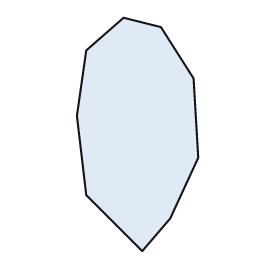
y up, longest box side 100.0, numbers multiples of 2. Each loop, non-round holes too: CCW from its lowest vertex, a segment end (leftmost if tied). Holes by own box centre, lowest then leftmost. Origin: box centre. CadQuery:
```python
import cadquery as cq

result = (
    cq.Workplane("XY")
    .moveTo(2.0, -50.0)
    .lineTo(14.0, -36.0)
    .lineTo(26.0, -10.0)
    .lineTo(24.0, 24.0)
    .lineTo(10.0, 46.0)
    .lineTo(-6.0, 50.0)
    .lineTo(-22.0, 36.0)
    .lineTo(-26.0, 8.0)
    .lineTo(-22.0, -26.0)
    .close()
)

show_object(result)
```